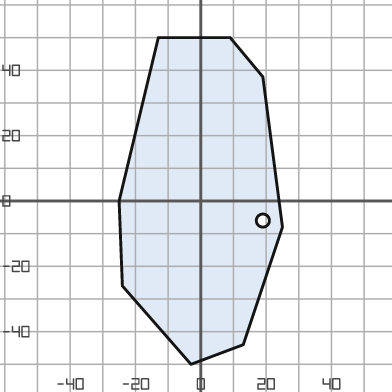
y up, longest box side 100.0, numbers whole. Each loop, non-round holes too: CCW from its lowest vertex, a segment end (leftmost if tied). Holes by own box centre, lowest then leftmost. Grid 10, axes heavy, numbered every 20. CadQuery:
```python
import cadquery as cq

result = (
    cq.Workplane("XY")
    .moveTo(-3.0, -50.0)
    .lineTo(13.0, -44.0)
    .lineTo(25.0, -8.0)
    .lineTo(19.0, 38.0)
    .lineTo(9.0, 50.0)
    .lineTo(-13.0, 50.0)
    .lineTo(-25.0, 0.0)
    .lineTo(-24.0, -26.0)
    .close()
    .moveTo(19.0, -6.0)
    .circle(2.0)
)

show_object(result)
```